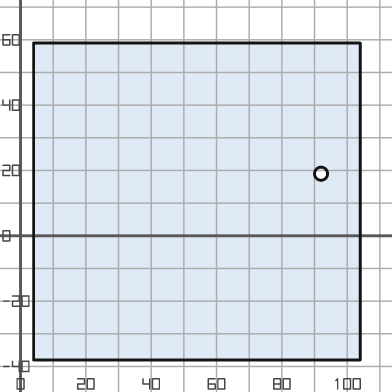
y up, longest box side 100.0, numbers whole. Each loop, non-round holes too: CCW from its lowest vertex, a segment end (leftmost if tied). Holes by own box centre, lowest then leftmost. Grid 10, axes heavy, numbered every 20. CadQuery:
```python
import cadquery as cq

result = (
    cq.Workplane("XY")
    .moveTo(4.0, -38.0)
    .lineTo(104.0, -38.0)
    .lineTo(104.0, 59.0)
    .lineTo(4.0, 59.0)
    .close()
    .moveTo(92.0, 19.0)
    .circle(2.0)
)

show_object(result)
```